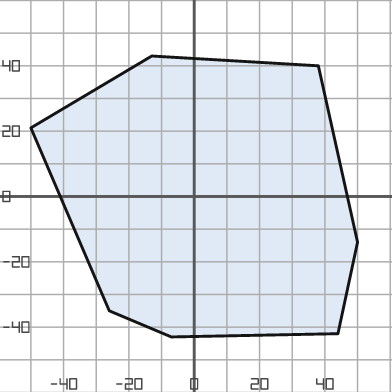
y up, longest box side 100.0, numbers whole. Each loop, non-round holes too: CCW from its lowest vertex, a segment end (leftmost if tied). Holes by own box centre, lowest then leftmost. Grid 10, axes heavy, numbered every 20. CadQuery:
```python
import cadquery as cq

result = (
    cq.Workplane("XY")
    .moveTo(-7.0, -43.0)
    .lineTo(44.0, -42.0)
    .lineTo(50.0, -14.0)
    .lineTo(38.0, 40.0)
    .lineTo(-13.0, 43.0)
    .lineTo(-50.0, 21.0)
    .lineTo(-26.0, -35.0)
    .close()
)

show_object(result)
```